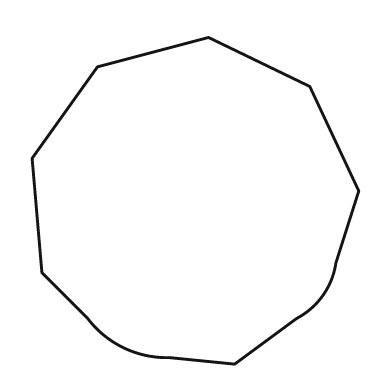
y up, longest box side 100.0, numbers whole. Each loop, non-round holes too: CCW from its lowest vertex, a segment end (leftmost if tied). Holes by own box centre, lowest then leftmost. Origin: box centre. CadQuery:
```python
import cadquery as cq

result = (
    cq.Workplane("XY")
    .moveTo(12.0, -50.0)
    .lineTo(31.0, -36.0)
    .threePointArc((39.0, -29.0), (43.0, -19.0))
    .lineTo(50.0, 3.0)
    .lineTo(35.0, 35.0)
    .lineTo(4.0, 50.0)
    .lineTo(-30.0, 41.0)
    .lineTo(-50.0, 13.0)
    .lineTo(-47.0, -22.0)
    .lineTo(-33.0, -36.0)
    .threePointArc((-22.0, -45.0), (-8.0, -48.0))
    .close()
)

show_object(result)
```